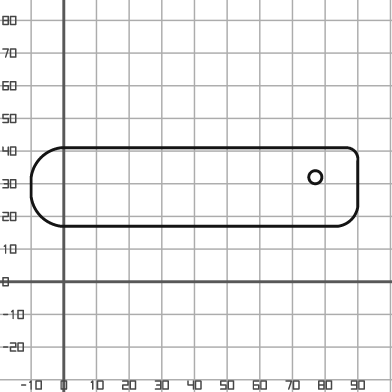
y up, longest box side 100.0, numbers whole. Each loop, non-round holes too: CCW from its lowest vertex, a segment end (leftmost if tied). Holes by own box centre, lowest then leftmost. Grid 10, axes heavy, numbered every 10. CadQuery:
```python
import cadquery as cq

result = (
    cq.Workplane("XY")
    .moveTo(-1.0, 17.0)
    .lineTo(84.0, 17.0)
    .threePointArc((88.0, 19.0), (90.0, 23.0))
    .lineTo(90.0, 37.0)
    .threePointArc((89.0, 40.0), (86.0, 41.0))
    .lineTo(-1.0, 41.0)
    .threePointArc((-7.0, 38.0), (-10.0, 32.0))
    .lineTo(-10.0, 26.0)
    .threePointArc((-7.0, 20.0), (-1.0, 17.0))
    .close()
    .moveTo(77.0, 32.0)
    .circle(2.0)
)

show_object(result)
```